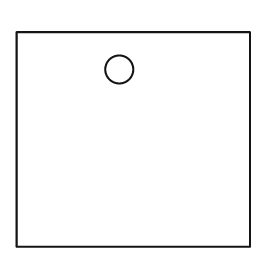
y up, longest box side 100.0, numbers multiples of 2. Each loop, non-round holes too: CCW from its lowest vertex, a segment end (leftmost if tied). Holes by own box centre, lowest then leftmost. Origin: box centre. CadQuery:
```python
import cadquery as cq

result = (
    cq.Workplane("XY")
    .moveTo(-50.0, -46.0)
    .lineTo(50.0, -46.0)
    .lineTo(50.0, 46.0)
    .lineTo(-50.0, 46.0)
    .close()
    .moveTo(-6.0, 30.0)
    .circle(6.0)
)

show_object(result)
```